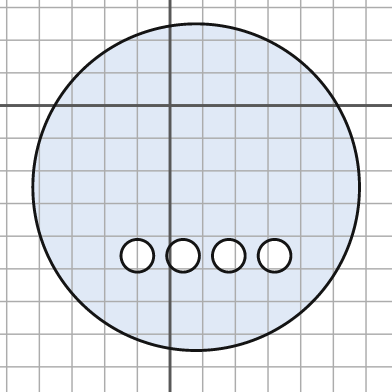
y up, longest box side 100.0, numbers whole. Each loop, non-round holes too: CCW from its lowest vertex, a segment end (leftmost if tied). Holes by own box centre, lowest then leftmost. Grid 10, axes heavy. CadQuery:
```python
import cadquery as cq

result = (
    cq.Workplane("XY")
    .moveTo(8.0, -25.0)
    .circle(50.0)
    .moveTo(-10.0, -46.0)
    .circle(5.0)
    .moveTo(4.0, -46.0)
    .circle(5.0)
    .moveTo(18.0, -46.0)
    .circle(5.0)
    .moveTo(32.0, -46.0)
    .circle(5.0)
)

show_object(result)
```